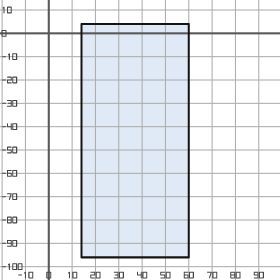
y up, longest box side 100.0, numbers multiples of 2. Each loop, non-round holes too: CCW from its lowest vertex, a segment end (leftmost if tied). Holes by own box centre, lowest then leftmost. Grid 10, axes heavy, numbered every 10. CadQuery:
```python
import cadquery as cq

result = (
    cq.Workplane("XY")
    .moveTo(14.0, -96.0)
    .lineTo(60.0, -96.0)
    .lineTo(60.0, 4.0)
    .lineTo(14.0, 4.0)
    .close()
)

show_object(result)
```